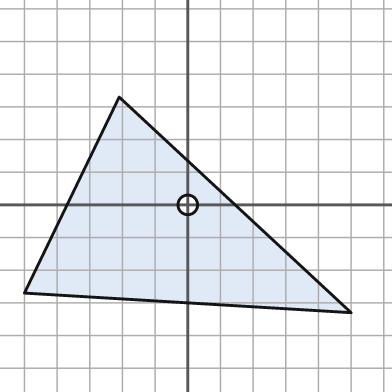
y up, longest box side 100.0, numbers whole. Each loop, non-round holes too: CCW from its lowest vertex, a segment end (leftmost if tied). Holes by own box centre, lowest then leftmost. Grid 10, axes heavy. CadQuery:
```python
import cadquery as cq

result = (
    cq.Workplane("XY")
    .moveTo(50.0, -33.0)
    .lineTo(-21.0, 33.0)
    .lineTo(-50.0, -27.0)
    .close()
    .moveTo(0.0, 0.0)
    .circle(3.0)
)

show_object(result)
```